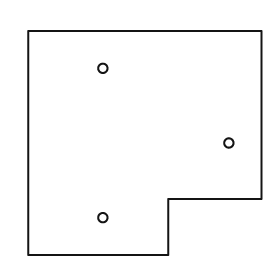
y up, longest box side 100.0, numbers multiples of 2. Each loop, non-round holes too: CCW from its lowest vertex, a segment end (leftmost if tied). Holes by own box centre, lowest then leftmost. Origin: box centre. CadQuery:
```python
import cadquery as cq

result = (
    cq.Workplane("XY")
    .moveTo(-50.0, -48.0)
    .lineTo(10.0, -48.0)
    .lineTo(10.0, -24.0)
    .lineTo(50.0, -24.0)
    .lineTo(50.0, 48.0)
    .lineTo(-50.0, 48.0)
    .close()
    .moveTo(-18.0, -32.0)
    .circle(2.0)
    .moveTo(36.0, 0.0)
    .circle(2.0)
    .moveTo(-18.0, 32.0)
    .circle(2.0)
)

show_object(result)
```